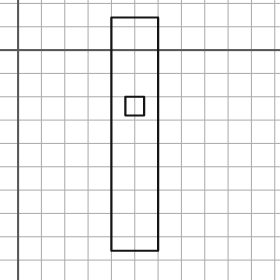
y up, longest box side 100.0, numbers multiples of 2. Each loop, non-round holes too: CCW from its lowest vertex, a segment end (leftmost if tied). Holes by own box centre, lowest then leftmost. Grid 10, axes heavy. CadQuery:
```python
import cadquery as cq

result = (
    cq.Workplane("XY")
    .moveTo(40.0, -86.0)
    .lineTo(60.0, -86.0)
    .lineTo(60.0, 14.0)
    .lineTo(40.0, 14.0)
    .close()
    .moveTo(46.0, -28.0)
    .lineTo(54.0, -28.0)
    .lineTo(54.0, -20.0)
    .lineTo(46.0, -20.0)
    .close()
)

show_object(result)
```